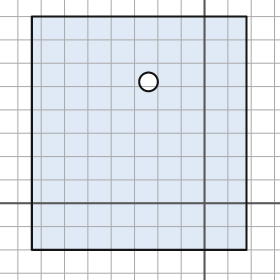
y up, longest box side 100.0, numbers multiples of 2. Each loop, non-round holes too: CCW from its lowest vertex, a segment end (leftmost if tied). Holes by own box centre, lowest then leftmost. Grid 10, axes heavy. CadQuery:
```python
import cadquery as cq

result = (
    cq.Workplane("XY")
    .moveTo(-74.0, -20.0)
    .lineTo(18.0, -20.0)
    .lineTo(18.0, 80.0)
    .lineTo(-74.0, 80.0)
    .close()
    .moveTo(-24.0, 52.0)
    .circle(4.0)
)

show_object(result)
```